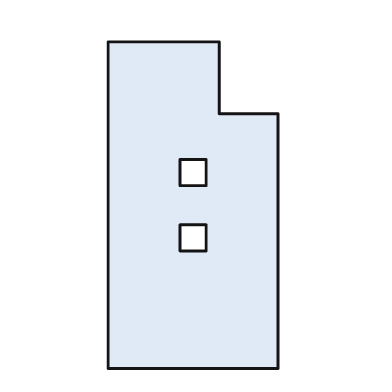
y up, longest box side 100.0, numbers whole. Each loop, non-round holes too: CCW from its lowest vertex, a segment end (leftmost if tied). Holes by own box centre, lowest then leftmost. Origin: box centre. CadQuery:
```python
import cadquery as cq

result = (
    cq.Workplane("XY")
    .moveTo(-26.0, -50.0)
    .lineTo(26.0, -50.0)
    .lineTo(26.0, 28.0)
    .lineTo(8.0, 28.0)
    .lineTo(8.0, 50.0)
    .lineTo(-26.0, 50.0)
    .close()
    .moveTo(-4.0, -14.0)
    .lineTo(4.0, -14.0)
    .lineTo(4.0, -6.0)
    .lineTo(-4.0, -6.0)
    .close()
    .moveTo(-4.0, 6.0)
    .lineTo(4.0, 6.0)
    .lineTo(4.0, 14.0)
    .lineTo(-4.0, 14.0)
    .close()
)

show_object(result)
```